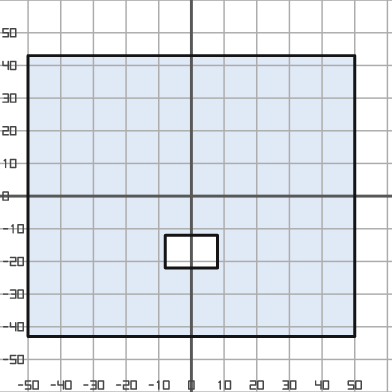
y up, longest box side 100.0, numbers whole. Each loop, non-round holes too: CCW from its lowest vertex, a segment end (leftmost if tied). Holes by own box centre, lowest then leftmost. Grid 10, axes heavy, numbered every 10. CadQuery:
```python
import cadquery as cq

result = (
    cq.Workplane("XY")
    .moveTo(-50.0, -43.0)
    .lineTo(50.0, -43.0)
    .lineTo(50.0, 43.0)
    .lineTo(-50.0, 43.0)
    .close()
    .moveTo(-8.0, -22.0)
    .lineTo(8.0, -22.0)
    .lineTo(8.0, -12.0)
    .lineTo(-8.0, -12.0)
    .close()
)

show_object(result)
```